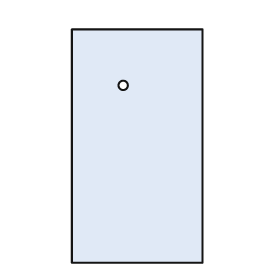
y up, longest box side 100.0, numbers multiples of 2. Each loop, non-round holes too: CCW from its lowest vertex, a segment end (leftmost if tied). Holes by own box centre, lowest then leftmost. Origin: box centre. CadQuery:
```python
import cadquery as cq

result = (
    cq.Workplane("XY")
    .moveTo(-28.0, -50.0)
    .lineTo(28.0, -50.0)
    .lineTo(28.0, 50.0)
    .lineTo(-28.0, 50.0)
    .close()
    .moveTo(-6.0, 26.0)
    .circle(2.0)
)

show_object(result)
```